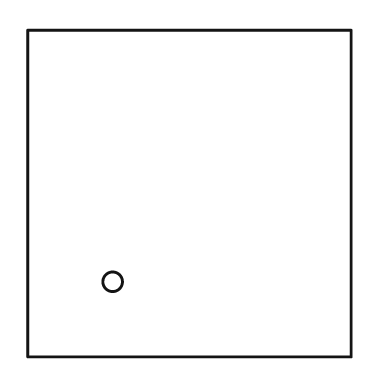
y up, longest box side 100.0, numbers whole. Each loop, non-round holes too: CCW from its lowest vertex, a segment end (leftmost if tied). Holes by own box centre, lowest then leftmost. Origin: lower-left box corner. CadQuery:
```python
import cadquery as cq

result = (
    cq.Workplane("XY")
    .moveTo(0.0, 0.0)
    .lineTo(99.0, 0.0)
    .lineTo(99.0, 100.0)
    .lineTo(0.0, 100.0)
    .close()
    .moveTo(26.0, 23.0)
    .circle(3.0)
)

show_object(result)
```